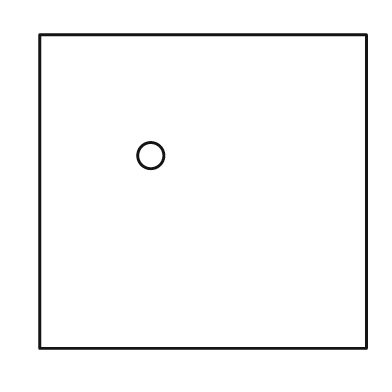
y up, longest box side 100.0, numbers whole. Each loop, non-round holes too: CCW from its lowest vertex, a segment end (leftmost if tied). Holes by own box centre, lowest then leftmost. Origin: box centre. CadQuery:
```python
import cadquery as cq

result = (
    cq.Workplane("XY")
    .moveTo(-50.0, -48.0)
    .lineTo(50.0, -48.0)
    .lineTo(50.0, 48.0)
    .lineTo(-50.0, 48.0)
    .close()
    .moveTo(-16.0, 11.0)
    .circle(4.0)
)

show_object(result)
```